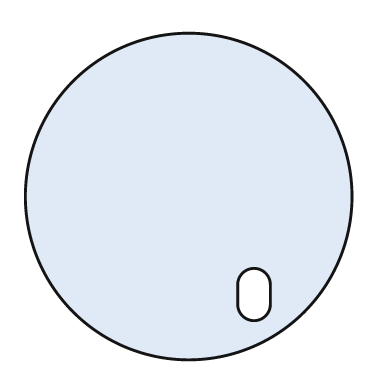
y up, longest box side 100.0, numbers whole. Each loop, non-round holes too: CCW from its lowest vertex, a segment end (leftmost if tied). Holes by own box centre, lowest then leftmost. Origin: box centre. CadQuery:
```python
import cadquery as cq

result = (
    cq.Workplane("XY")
    .moveTo(0.0, 0.0)
    .circle(50.0)
    .moveTo(15.0, -33.0)
    .threePointArc((20.0, -38.0), (25.0, -33.0))
    .lineTo(25.0, -27.0)
    .threePointArc((20.0, -22.0), (15.0, -27.0))
    .close()
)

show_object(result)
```